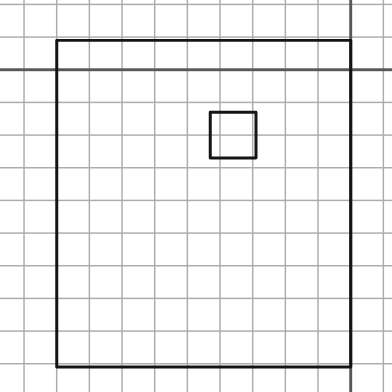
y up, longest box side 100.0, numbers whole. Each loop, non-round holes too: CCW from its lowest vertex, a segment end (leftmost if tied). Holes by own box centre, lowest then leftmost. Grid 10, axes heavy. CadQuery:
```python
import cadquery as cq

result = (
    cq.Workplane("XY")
    .moveTo(-90.0, -91.0)
    .lineTo(0.0, -91.0)
    .lineTo(0.0, 9.0)
    .lineTo(-90.0, 9.0)
    .close()
    .moveTo(-43.0, -27.0)
    .lineTo(-29.0, -27.0)
    .lineTo(-29.0, -13.0)
    .lineTo(-43.0, -13.0)
    .close()
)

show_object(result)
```